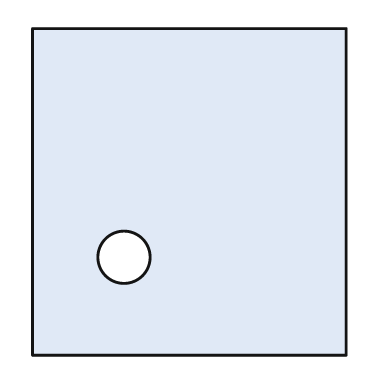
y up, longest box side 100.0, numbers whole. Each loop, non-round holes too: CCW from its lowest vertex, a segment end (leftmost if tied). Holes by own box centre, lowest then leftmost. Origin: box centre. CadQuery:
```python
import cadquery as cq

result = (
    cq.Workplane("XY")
    .moveTo(-48.0, -50.0)
    .lineTo(48.0, -50.0)
    .lineTo(48.0, 50.0)
    .lineTo(-48.0, 50.0)
    .close()
    .moveTo(-20.0, -20.0)
    .circle(8.0)
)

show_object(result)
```